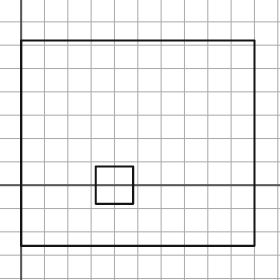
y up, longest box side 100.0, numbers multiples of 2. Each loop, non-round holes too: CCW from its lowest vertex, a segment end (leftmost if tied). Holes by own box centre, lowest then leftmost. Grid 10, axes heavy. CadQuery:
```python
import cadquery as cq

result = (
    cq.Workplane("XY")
    .moveTo(0.0, -26.0)
    .lineTo(100.0, -26.0)
    .lineTo(100.0, 62.0)
    .lineTo(0.0, 62.0)
    .close()
    .moveTo(32.0, -8.0)
    .lineTo(48.0, -8.0)
    .lineTo(48.0, 8.0)
    .lineTo(32.0, 8.0)
    .close()
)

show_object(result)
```